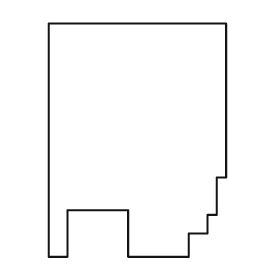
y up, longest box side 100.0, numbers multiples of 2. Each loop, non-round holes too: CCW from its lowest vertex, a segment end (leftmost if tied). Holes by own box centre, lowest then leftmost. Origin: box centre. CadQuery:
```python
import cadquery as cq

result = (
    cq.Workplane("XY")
    .moveTo(-38.0, -50.0)
    .lineTo(-30.0, -50.0)
    .lineTo(-30.0, -30.0)
    .lineTo(-4.0, -30.0)
    .lineTo(-4.0, -50.0)
    .lineTo(22.0, -50.0)
    .lineTo(22.0, -40.0)
    .lineTo(30.0, -40.0)
    .lineTo(30.0, -32.0)
    .lineTo(34.0, -32.0)
    .lineTo(34.0, -16.0)
    .lineTo(38.0, -16.0)
    .lineTo(38.0, 50.0)
    .lineTo(-38.0, 50.0)
    .close()
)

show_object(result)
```